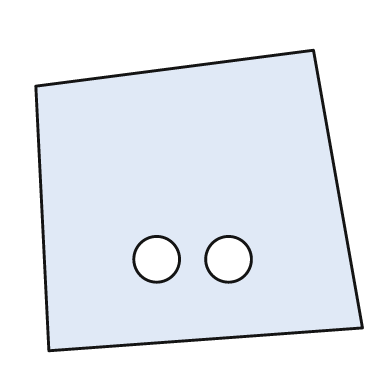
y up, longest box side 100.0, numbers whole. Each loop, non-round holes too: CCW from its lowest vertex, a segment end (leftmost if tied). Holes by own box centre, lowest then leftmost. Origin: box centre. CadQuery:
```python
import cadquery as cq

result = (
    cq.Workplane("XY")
    .moveTo(-46.0, -46.0)
    .lineTo(50.0, -39.0)
    .lineTo(35.0, 46.0)
    .lineTo(-50.0, 35.0)
    .close()
    .moveTo(-13.0, -18.0)
    .circle(7.0)
    .moveTo(9.0, -18.0)
    .circle(7.0)
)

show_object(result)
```